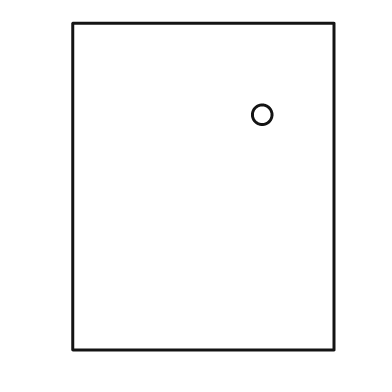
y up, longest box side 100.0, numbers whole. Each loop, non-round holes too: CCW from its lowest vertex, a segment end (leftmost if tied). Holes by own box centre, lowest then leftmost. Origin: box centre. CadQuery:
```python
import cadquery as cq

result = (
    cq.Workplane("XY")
    .moveTo(-40.0, -50.0)
    .lineTo(40.0, -50.0)
    .lineTo(40.0, 50.0)
    .lineTo(-40.0, 50.0)
    .close()
    .moveTo(18.0, 22.0)
    .circle(3.0)
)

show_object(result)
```